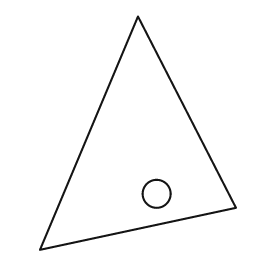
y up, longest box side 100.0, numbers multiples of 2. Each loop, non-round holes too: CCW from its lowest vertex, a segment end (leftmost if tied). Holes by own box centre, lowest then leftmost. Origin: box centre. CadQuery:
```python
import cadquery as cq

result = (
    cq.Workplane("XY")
    .moveTo(-42.0, -50.0)
    .lineTo(42.0, -32.0)
    .lineTo(0.0, 50.0)
    .close()
    .moveTo(8.0, -26.0)
    .circle(6.0)
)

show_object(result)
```